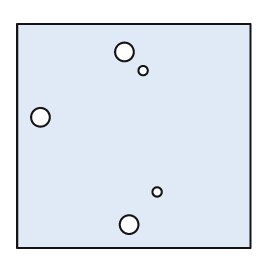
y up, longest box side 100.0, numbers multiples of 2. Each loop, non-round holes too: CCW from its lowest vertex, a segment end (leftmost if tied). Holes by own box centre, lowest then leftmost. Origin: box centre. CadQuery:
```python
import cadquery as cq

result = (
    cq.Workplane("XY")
    .moveTo(-50.0, -48.0)
    .lineTo(50.0, -48.0)
    .lineTo(50.0, 48.0)
    .lineTo(-50.0, 48.0)
    .close()
    .moveTo(-2.0, -38.0)
    .circle(4.0)
    .moveTo(10.0, -24.0)
    .circle(2.0)
    .moveTo(-40.0, 8.0)
    .circle(4.0)
    .moveTo(4.0, 28.0)
    .circle(2.0)
    .moveTo(-4.0, 36.0)
    .circle(4.0)
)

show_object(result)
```